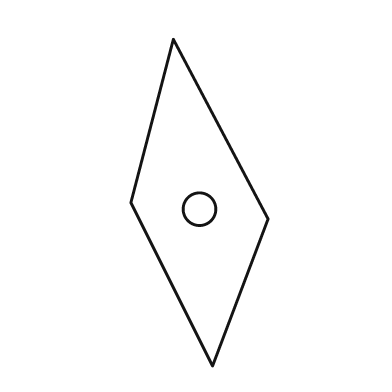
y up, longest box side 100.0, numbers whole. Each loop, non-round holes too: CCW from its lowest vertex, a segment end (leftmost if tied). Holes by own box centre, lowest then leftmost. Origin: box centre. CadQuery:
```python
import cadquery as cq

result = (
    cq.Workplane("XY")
    .moveTo(4.0, -50.0)
    .lineTo(21.0, -5.0)
    .lineTo(-8.0, 50.0)
    .lineTo(-21.0, 0.0)
    .close()
    .moveTo(0.0, -2.0)
    .circle(5.0)
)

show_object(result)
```